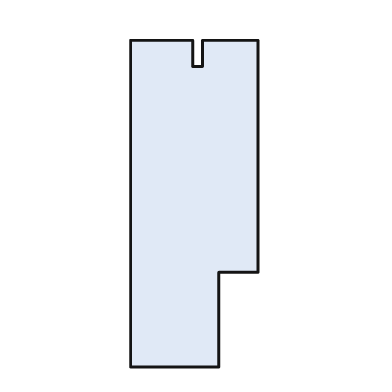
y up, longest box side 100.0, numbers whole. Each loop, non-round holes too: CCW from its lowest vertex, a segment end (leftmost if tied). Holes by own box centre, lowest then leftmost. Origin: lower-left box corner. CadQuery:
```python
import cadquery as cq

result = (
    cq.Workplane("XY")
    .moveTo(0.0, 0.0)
    .lineTo(27.0, 0.0)
    .lineTo(27.0, 29.0)
    .lineTo(39.0, 29.0)
    .lineTo(39.0, 100.0)
    .lineTo(22.0, 100.0)
    .lineTo(22.0, 92.0)
    .lineTo(19.0, 92.0)
    .lineTo(19.0, 100.0)
    .lineTo(0.0, 100.0)
    .close()
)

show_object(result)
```